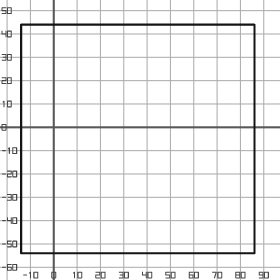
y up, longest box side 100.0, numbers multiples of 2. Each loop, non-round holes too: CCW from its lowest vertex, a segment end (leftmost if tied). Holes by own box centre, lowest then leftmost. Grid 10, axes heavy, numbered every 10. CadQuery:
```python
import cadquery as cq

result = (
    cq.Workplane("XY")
    .moveTo(-14.0, -54.0)
    .lineTo(86.0, -54.0)
    .lineTo(86.0, 44.0)
    .lineTo(-14.0, 44.0)
    .close()
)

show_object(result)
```